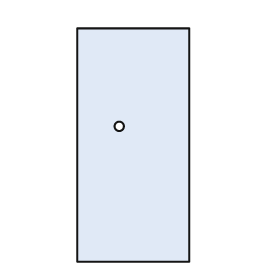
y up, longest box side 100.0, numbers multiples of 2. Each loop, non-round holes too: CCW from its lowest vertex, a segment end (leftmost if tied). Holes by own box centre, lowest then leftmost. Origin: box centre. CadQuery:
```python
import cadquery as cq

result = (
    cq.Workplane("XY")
    .moveTo(-24.0, -50.0)
    .lineTo(24.0, -50.0)
    .lineTo(24.0, 50.0)
    .lineTo(-24.0, 50.0)
    .close()
    .moveTo(-6.0, 8.0)
    .circle(2.0)
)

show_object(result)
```